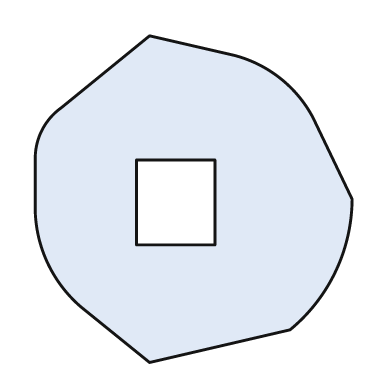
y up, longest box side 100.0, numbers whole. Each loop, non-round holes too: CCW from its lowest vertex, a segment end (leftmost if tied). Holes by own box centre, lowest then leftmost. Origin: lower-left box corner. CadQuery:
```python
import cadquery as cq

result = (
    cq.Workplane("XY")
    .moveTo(35.0, 0.0)
    .lineTo(78.0, 10.0)
    .threePointArc((92.0, 28.0), (97.0, 50.0))
    .lineTo(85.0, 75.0)
    .threePointArc((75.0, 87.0), (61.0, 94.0))
    .lineTo(35.0, 100.0)
    .lineTo(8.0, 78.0)
    .threePointArc((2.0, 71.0), (0.0, 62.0))
    .lineTo(0.0, 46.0)
    .threePointArc((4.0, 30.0), (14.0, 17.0))
    .close()
    .moveTo(31.0, 36.0)
    .lineTo(55.0, 36.0)
    .lineTo(55.0, 62.0)
    .lineTo(31.0, 62.0)
    .close()
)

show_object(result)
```